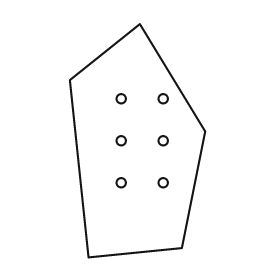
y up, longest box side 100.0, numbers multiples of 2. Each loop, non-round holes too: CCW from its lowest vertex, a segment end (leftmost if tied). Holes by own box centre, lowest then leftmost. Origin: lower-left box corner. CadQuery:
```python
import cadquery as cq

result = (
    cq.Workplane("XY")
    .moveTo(8.0, 0.0)
    .lineTo(48.0, 4.0)
    .lineTo(58.0, 54.0)
    .lineTo(30.0, 100.0)
    .lineTo(0.0, 76.0)
    .close()
    .moveTo(22.0, 32.0)
    .circle(2.0)
    .moveTo(40.0, 32.0)
    .circle(2.0)
    .moveTo(22.0, 50.0)
    .circle(2.0)
    .moveTo(40.0, 50.0)
    .circle(2.0)
    .moveTo(22.0, 68.0)
    .circle(2.0)
    .moveTo(40.0, 68.0)
    .circle(2.0)
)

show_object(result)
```